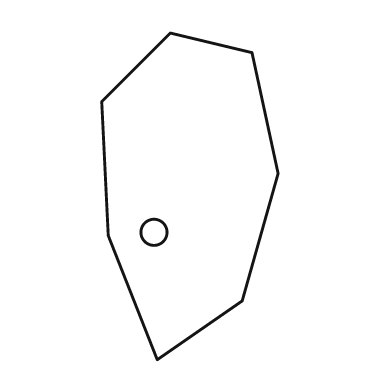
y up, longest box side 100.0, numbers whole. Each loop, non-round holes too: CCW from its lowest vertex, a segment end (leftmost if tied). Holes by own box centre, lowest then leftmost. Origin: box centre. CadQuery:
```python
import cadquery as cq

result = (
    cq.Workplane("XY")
    .moveTo(-10.0, -50.0)
    .lineTo(16.0, -32.0)
    .lineTo(27.0, 7.0)
    .lineTo(19.0, 44.0)
    .lineTo(-6.0, 50.0)
    .lineTo(-27.0, 29.0)
    .lineTo(-25.0, -12.0)
    .close()
    .moveTo(-11.0, -11.0)
    .circle(4.0)
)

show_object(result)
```